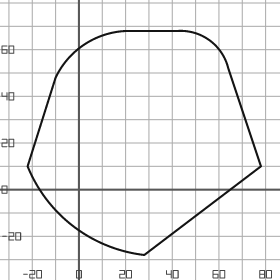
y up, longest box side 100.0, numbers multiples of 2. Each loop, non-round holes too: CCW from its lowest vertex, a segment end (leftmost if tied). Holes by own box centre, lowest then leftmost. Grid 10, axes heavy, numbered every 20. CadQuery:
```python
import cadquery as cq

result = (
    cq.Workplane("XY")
    .moveTo(28.0, -28.0)
    .lineTo(78.0, 10.0)
    .lineTo(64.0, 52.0)
    .threePointArc((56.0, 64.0), (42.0, 68.0))
    .lineTo(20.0, 68.0)
    .threePointArc((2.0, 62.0), (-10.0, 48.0))
    .lineTo(-22.0, 10.0)
    .threePointArc((-2.0, -16.0), (28.0, -28.0))
    .close()
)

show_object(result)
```